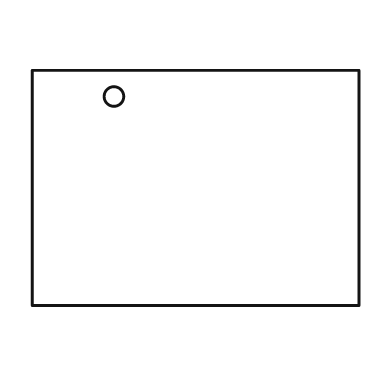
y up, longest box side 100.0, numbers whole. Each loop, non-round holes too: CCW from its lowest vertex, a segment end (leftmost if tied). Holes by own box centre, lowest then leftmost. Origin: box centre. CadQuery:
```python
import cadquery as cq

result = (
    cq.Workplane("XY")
    .moveTo(-50.0, -36.0)
    .lineTo(50.0, -36.0)
    .lineTo(50.0, 36.0)
    .lineTo(-50.0, 36.0)
    .close()
    .moveTo(-25.0, 28.0)
    .circle(3.0)
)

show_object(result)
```